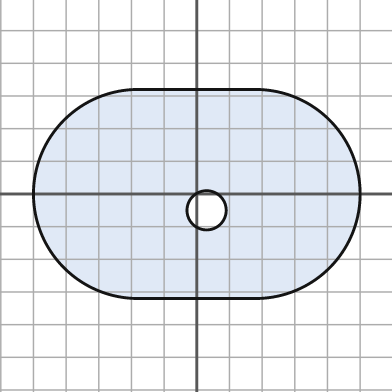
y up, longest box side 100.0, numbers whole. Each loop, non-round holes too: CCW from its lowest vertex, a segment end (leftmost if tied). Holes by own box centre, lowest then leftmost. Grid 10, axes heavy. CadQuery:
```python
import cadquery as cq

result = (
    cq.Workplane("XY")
    .moveTo(-18.0, -32.0)
    .lineTo(18.0, -32.0)
    .threePointArc((50.0, 0.0), (18.0, 32.0))
    .lineTo(-18.0, 32.0)
    .threePointArc((-50.0, 0.0), (-18.0, -32.0))
    .close()
    .moveTo(3.0, -5.0)
    .circle(6.0)
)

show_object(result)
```